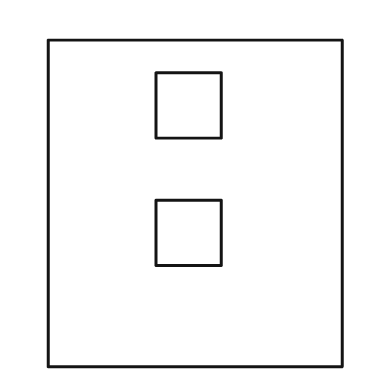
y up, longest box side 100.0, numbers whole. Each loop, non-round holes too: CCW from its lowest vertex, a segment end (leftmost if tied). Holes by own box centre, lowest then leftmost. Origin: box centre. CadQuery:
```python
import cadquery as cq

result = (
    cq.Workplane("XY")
    .moveTo(-45.0, -50.0)
    .lineTo(45.0, -50.0)
    .lineTo(45.0, 50.0)
    .lineTo(-45.0, 50.0)
    .close()
    .moveTo(-12.0, -19.0)
    .lineTo(8.0, -19.0)
    .lineTo(8.0, 1.0)
    .lineTo(-12.0, 1.0)
    .close()
    .moveTo(-12.0, 20.0)
    .lineTo(8.0, 20.0)
    .lineTo(8.0, 40.0)
    .lineTo(-12.0, 40.0)
    .close()
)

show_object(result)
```